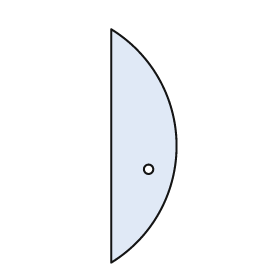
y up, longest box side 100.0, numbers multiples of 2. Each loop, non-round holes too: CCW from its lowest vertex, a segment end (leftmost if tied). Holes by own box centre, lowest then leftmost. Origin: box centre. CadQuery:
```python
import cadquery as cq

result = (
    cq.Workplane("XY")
    .moveTo(-14.0, -50.0)
    .threePointArc((14.0, 0.0), (-14.0, 50.0))
    .close()
    .moveTo(2.0, -10.0)
    .circle(2.0)
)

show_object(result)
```